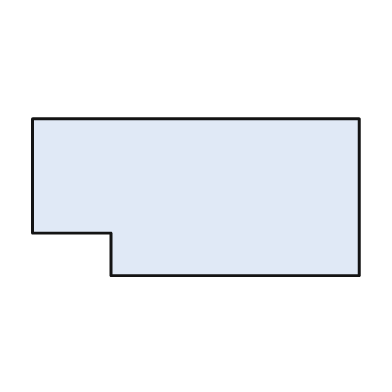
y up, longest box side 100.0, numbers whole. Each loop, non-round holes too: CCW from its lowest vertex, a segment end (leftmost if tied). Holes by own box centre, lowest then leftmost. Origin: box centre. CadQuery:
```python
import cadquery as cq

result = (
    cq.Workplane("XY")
    .moveTo(-26.0, -24.0)
    .lineTo(50.0, -24.0)
    .lineTo(50.0, 24.0)
    .lineTo(-50.0, 24.0)
    .lineTo(-50.0, -11.0)
    .lineTo(-26.0, -11.0)
    .close()
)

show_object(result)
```